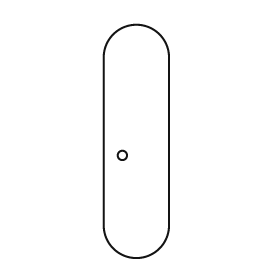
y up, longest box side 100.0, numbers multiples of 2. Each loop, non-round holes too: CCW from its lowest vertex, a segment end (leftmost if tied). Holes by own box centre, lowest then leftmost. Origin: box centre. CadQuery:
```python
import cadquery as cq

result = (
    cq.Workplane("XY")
    .moveTo(-14.0, -36.0)
    .threePointArc((0.0, -50.0), (14.0, -36.0))
    .lineTo(14.0, 36.0)
    .threePointArc((0.0, 50.0), (-14.0, 36.0))
    .close()
    .moveTo(-6.0, -6.0)
    .circle(2.0)
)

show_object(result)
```